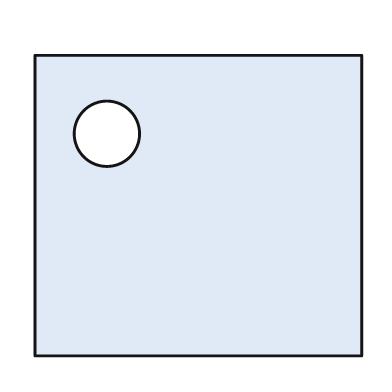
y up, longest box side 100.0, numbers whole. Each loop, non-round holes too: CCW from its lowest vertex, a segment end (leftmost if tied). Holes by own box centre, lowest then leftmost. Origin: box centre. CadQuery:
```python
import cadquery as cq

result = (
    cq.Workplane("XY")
    .moveTo(-50.0, -46.0)
    .lineTo(50.0, -46.0)
    .lineTo(50.0, 46.0)
    .lineTo(-50.0, 46.0)
    .close()
    .moveTo(-28.0, 22.0)
    .circle(10.0)
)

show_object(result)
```